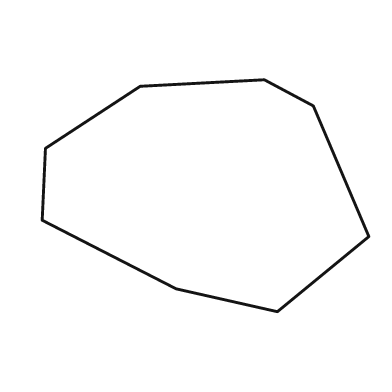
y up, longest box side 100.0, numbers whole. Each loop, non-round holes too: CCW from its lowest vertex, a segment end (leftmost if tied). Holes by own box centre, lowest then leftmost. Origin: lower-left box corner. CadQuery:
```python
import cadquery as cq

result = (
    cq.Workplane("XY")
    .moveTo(72.0, 0.0)
    .lineTo(100.0, 23.0)
    .lineTo(83.0, 63.0)
    .lineTo(68.0, 71.0)
    .lineTo(30.0, 69.0)
    .lineTo(1.0, 50.0)
    .lineTo(0.0, 28.0)
    .lineTo(41.0, 7.0)
    .close()
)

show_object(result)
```